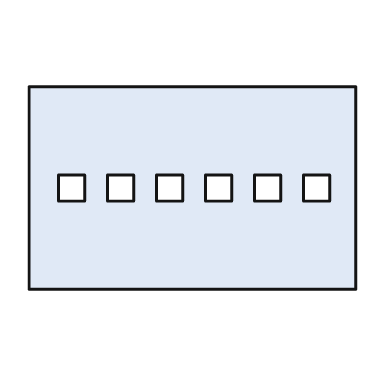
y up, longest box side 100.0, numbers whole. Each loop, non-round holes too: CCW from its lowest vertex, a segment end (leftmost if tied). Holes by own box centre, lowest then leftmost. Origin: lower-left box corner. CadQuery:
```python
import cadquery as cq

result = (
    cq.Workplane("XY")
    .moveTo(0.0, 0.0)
    .lineTo(100.0, 0.0)
    .lineTo(100.0, 62.0)
    .lineTo(0.0, 62.0)
    .close()
    .moveTo(9.0, 27.0)
    .lineTo(17.0, 27.0)
    .lineTo(17.0, 35.0)
    .lineTo(9.0, 35.0)
    .close()
    .moveTo(24.0, 27.0)
    .lineTo(32.0, 27.0)
    .lineTo(32.0, 35.0)
    .lineTo(24.0, 35.0)
    .close()
    .moveTo(39.0, 27.0)
    .lineTo(47.0, 27.0)
    .lineTo(47.0, 35.0)
    .lineTo(39.0, 35.0)
    .close()
    .moveTo(54.0, 27.0)
    .lineTo(62.0, 27.0)
    .lineTo(62.0, 35.0)
    .lineTo(54.0, 35.0)
    .close()
    .moveTo(69.0, 27.0)
    .lineTo(77.0, 27.0)
    .lineTo(77.0, 35.0)
    .lineTo(69.0, 35.0)
    .close()
    .moveTo(84.0, 27.0)
    .lineTo(92.0, 27.0)
    .lineTo(92.0, 35.0)
    .lineTo(84.0, 35.0)
    .close()
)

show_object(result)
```